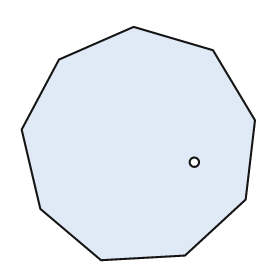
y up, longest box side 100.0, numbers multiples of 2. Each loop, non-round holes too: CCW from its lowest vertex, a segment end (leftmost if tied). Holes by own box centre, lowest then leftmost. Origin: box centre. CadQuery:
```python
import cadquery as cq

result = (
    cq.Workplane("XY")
    .moveTo(-16.0, -50.0)
    .lineTo(20.0, -48.0)
    .lineTo(46.0, -24.0)
    .lineTo(50.0, 10.0)
    .lineTo(32.0, 40.0)
    .lineTo(-2.0, 50.0)
    .lineTo(-34.0, 36.0)
    .lineTo(-50.0, 6.0)
    .lineTo(-42.0, -28.0)
    .close()
    .moveTo(24.0, -8.0)
    .circle(2.0)
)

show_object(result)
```